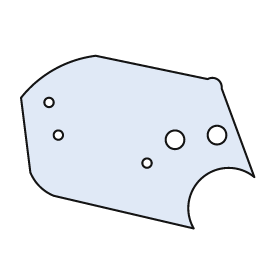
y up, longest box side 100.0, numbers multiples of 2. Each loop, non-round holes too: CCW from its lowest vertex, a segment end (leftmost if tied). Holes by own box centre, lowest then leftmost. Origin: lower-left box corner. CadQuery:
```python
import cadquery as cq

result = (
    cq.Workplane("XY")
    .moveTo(74.0, 0.0)
    .threePointArc((78.0, 22.0), (100.0, 22.0))
    .lineTo(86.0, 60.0)
    .threePointArc((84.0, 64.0), (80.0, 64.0))
    .lineTo(32.0, 74.0)
    .threePointArc((14.0, 68.0), (0.0, 56.0))
    .lineTo(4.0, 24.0)
    .threePointArc((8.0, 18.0), (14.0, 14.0))
    .close()
    .moveTo(54.0, 28.0)
    .circle(2.0)
    .moveTo(66.0, 38.0)
    .circle(4.0)
    .moveTo(16.0, 40.0)
    .circle(2.0)
    .moveTo(84.0, 40.0)
    .circle(4.0)
    .moveTo(12.0, 54.0)
    .circle(2.0)
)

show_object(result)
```